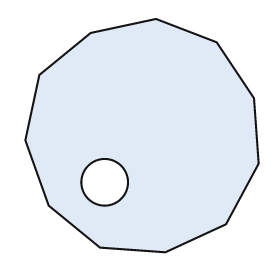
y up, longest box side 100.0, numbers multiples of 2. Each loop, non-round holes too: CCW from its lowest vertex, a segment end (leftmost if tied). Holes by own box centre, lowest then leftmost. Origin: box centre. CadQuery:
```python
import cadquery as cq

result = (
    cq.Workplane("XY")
    .moveTo(10.0, -50.0)
    .lineTo(36.0, -38.0)
    .lineTo(50.0, -12.0)
    .lineTo(48.0, 16.0)
    .lineTo(32.0, 40.0)
    .lineTo(6.0, 50.0)
    .lineTo(-22.0, 44.0)
    .lineTo(-44.0, 26.0)
    .lineTo(-50.0, -2.0)
    .lineTo(-40.0, -30.0)
    .lineTo(-18.0, -48.0)
    .close()
    .moveTo(-16.0, -20.0)
    .circle(10.0)
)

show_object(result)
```